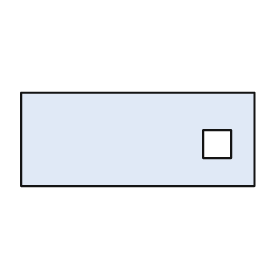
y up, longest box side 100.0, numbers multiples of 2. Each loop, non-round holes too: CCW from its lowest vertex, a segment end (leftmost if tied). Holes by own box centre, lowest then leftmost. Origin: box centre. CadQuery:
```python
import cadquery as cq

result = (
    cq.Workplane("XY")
    .moveTo(-50.0, -20.0)
    .lineTo(50.0, -20.0)
    .lineTo(50.0, 20.0)
    .lineTo(-50.0, 20.0)
    .close()
    .moveTo(28.0, -8.0)
    .lineTo(40.0, -8.0)
    .lineTo(40.0, 4.0)
    .lineTo(28.0, 4.0)
    .close()
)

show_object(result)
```